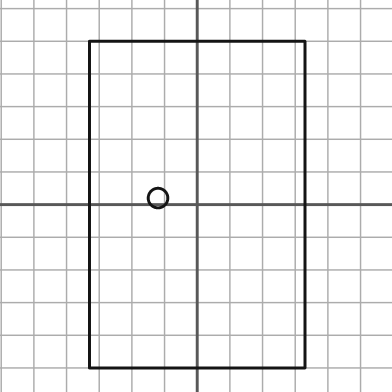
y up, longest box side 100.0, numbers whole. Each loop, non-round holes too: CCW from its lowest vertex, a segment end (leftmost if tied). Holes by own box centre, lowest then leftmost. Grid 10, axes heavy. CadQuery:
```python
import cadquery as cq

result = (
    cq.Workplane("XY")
    .moveTo(-33.0, -50.0)
    .lineTo(33.0, -50.0)
    .lineTo(33.0, 50.0)
    .lineTo(-33.0, 50.0)
    .close()
    .moveTo(-12.0, 2.0)
    .circle(3.0)
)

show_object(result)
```